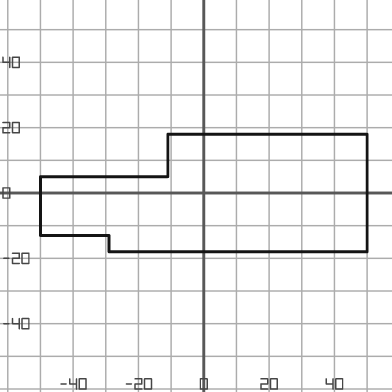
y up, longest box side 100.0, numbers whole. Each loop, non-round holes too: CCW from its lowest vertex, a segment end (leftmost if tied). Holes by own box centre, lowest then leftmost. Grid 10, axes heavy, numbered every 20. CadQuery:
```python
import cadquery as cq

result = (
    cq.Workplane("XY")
    .moveTo(-29.0, -18.0)
    .lineTo(50.0, -18.0)
    .lineTo(50.0, 18.0)
    .lineTo(-11.0, 18.0)
    .lineTo(-11.0, 5.0)
    .lineTo(-50.0, 5.0)
    .lineTo(-50.0, -13.0)
    .lineTo(-29.0, -13.0)
    .close()
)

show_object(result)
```